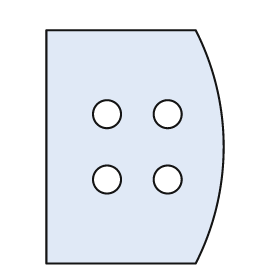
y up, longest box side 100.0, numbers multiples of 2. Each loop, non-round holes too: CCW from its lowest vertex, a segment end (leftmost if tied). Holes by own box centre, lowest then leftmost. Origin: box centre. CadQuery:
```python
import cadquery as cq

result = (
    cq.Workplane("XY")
    .moveTo(-38.0, -50.0)
    .lineTo(26.0, -50.0)
    .threePointArc((38.0, 0.0), (26.0, 50.0))
    .lineTo(-38.0, 50.0)
    .close()
    .moveTo(-12.0, -14.0)
    .circle(6.0)
    .moveTo(14.0, -14.0)
    .circle(6.0)
    .moveTo(-12.0, 14.0)
    .circle(6.0)
    .moveTo(14.0, 14.0)
    .circle(6.0)
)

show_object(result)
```